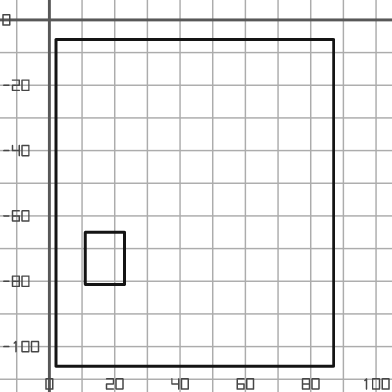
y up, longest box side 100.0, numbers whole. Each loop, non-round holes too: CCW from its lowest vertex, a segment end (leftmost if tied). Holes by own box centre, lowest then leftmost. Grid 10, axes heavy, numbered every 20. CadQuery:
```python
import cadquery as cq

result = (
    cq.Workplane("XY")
    .moveTo(2.0, -106.0)
    .lineTo(87.0, -106.0)
    .lineTo(87.0, -6.0)
    .lineTo(2.0, -6.0)
    .close()
    .moveTo(11.0, -81.0)
    .lineTo(23.0, -81.0)
    .lineTo(23.0, -65.0)
    .lineTo(11.0, -65.0)
    .close()
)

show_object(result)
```